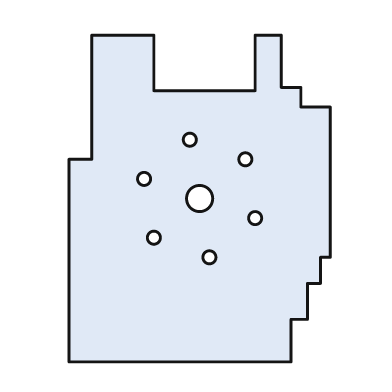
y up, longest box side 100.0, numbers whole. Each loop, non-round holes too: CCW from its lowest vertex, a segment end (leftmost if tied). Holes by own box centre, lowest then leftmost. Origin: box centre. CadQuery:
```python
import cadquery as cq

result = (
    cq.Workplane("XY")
    .moveTo(-40.0, -50.0)
    .lineTo(28.0, -50.0)
    .lineTo(28.0, -37.0)
    .lineTo(33.0, -37.0)
    .lineTo(33.0, -26.0)
    .lineTo(37.0, -26.0)
    .lineTo(37.0, -18.0)
    .lineTo(40.0, -18.0)
    .lineTo(40.0, 28.0)
    .lineTo(31.0, 28.0)
    .lineTo(31.0, 34.0)
    .lineTo(25.0, 34.0)
    .lineTo(25.0, 50.0)
    .lineTo(17.0, 50.0)
    .lineTo(17.0, 33.0)
    .lineTo(-14.0, 33.0)
    .lineTo(-14.0, 50.0)
    .lineTo(-33.0, 50.0)
    .lineTo(-33.0, 12.0)
    .lineTo(-40.0, 12.0)
    .close()
    .moveTo(3.0, -18.0)
    .circle(2.0)
    .moveTo(-14.0, -12.0)
    .circle(2.0)
    .moveTo(17.0, -6.0)
    .circle(2.0)
    .moveTo(0.0, 0.0)
    .circle(4.0)
    .moveTo(-17.0, 6.0)
    .circle(2.0)
    .moveTo(14.0, 12.0)
    .circle(2.0)
    .moveTo(-3.0, 18.0)
    .circle(2.0)
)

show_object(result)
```